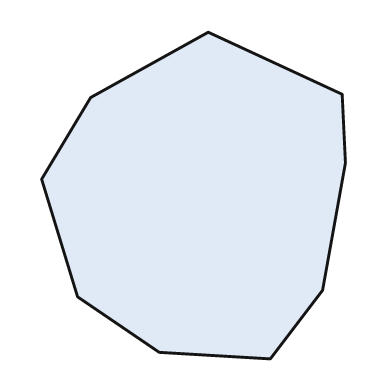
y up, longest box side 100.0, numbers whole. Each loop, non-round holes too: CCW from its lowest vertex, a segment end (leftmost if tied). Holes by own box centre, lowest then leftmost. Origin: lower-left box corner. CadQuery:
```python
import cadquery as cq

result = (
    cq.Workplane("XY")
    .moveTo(70.0, 0.0)
    .lineTo(86.0, 21.0)
    .lineTo(93.0, 60.0)
    .lineTo(92.0, 81.0)
    .lineTo(51.0, 100.0)
    .lineTo(15.0, 80.0)
    .lineTo(0.0, 55.0)
    .lineTo(11.0, 19.0)
    .lineTo(36.0, 2.0)
    .close()
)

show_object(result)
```